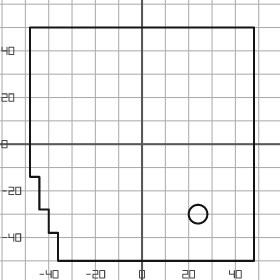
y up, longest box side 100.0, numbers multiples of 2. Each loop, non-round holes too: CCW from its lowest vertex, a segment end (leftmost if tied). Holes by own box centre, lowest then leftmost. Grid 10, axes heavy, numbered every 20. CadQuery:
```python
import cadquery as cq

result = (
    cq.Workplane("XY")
    .moveTo(-36.0, -50.0)
    .lineTo(48.0, -50.0)
    .lineTo(48.0, 50.0)
    .lineTo(-48.0, 50.0)
    .lineTo(-48.0, -14.0)
    .lineTo(-44.0, -14.0)
    .lineTo(-44.0, -28.0)
    .lineTo(-40.0, -28.0)
    .lineTo(-40.0, -38.0)
    .lineTo(-36.0, -38.0)
    .close()
    .moveTo(24.0, -30.0)
    .circle(4.0)
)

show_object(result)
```